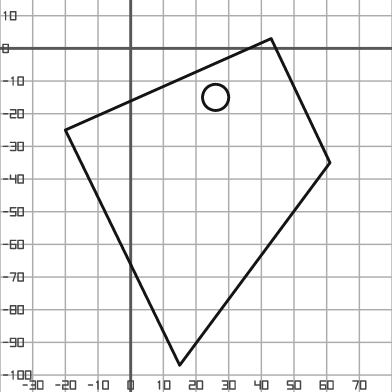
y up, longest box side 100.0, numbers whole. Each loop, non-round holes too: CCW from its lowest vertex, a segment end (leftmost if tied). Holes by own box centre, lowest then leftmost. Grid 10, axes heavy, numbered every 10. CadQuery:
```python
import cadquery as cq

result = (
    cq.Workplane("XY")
    .moveTo(15.0, -97.0)
    .lineTo(61.0, -35.0)
    .lineTo(43.0, 3.0)
    .lineTo(-20.0, -25.0)
    .close()
    .moveTo(26.0, -15.0)
    .circle(4.0)
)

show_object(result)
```